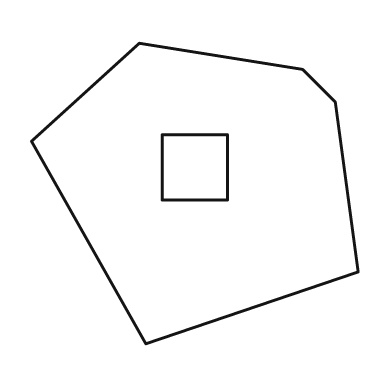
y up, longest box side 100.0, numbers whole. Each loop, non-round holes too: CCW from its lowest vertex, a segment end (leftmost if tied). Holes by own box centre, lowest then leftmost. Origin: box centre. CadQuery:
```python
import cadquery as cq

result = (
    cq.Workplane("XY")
    .moveTo(-15.0, -46.0)
    .lineTo(50.0, -24.0)
    .lineTo(43.0, 28.0)
    .lineTo(33.0, 38.0)
    .lineTo(-17.0, 46.0)
    .lineTo(-50.0, 16.0)
    .close()
    .moveTo(-10.0, -2.0)
    .lineTo(10.0, -2.0)
    .lineTo(10.0, 18.0)
    .lineTo(-10.0, 18.0)
    .close()
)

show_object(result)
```